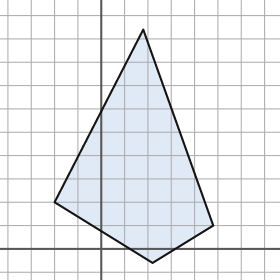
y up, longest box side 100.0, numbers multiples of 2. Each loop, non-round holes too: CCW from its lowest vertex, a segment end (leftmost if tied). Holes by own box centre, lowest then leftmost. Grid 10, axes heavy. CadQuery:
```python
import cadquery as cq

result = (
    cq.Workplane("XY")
    .moveTo(22.0, -6.0)
    .lineTo(48.0, 10.0)
    .lineTo(18.0, 94.0)
    .lineTo(-20.0, 20.0)
    .close()
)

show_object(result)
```